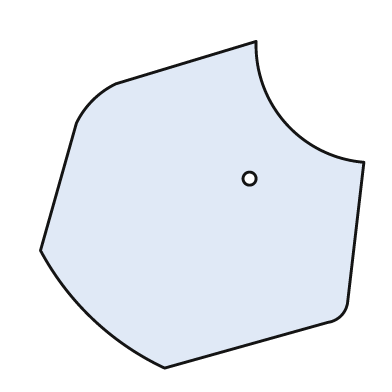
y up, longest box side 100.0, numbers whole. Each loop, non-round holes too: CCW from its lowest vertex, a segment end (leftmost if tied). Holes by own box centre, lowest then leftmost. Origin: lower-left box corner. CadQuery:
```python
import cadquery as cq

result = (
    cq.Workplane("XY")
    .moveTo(38.0, 0.0)
    .lineTo(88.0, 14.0)
    .threePointArc((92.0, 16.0), (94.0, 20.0))
    .lineTo(99.0, 63.0)
    .threePointArc((75.0, 75.0), (66.0, 100.0))
    .lineTo(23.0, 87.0)
    .threePointArc((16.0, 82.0), (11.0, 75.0))
    .lineTo(0.0, 36.0)
    .threePointArc((16.0, 15.0), (38.0, 0.0))
    .close()
    .moveTo(64.0, 58.0)
    .circle(2.0)
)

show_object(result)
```